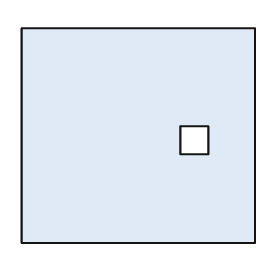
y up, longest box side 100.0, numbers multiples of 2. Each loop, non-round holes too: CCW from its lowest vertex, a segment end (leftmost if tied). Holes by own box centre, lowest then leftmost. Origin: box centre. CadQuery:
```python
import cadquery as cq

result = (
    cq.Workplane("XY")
    .moveTo(-50.0, -46.0)
    .lineTo(50.0, -46.0)
    .lineTo(50.0, 46.0)
    .lineTo(-50.0, 46.0)
    .close()
    .moveTo(18.0, -8.0)
    .lineTo(30.0, -8.0)
    .lineTo(30.0, 4.0)
    .lineTo(18.0, 4.0)
    .close()
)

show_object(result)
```